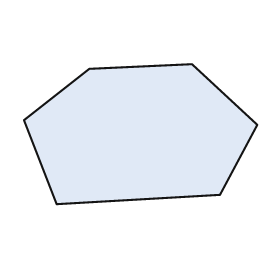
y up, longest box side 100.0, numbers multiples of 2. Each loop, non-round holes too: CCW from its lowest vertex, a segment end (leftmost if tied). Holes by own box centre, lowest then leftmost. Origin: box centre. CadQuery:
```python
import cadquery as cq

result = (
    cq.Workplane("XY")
    .moveTo(-36.0, -30.0)
    .lineTo(34.0, -26.0)
    .lineTo(50.0, 4.0)
    .lineTo(22.0, 30.0)
    .lineTo(-22.0, 28.0)
    .lineTo(-50.0, 6.0)
    .close()
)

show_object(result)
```